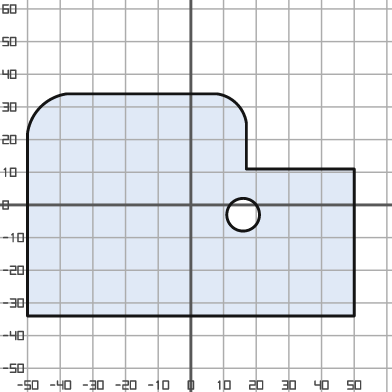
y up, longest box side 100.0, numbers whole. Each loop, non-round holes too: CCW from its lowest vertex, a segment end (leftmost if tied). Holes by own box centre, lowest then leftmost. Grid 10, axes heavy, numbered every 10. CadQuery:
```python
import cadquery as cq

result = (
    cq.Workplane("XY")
    .moveTo(-50.0, -34.0)
    .lineTo(50.0, -34.0)
    .lineTo(50.0, 11.0)
    .lineTo(17.0, 11.0)
    .lineTo(17.0, 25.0)
    .threePointArc((14.0, 31.0), (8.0, 34.0))
    .lineTo(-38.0, 34.0)
    .threePointArc((-46.0, 30.0), (-50.0, 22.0))
    .close()
    .moveTo(16.0, -3.0)
    .circle(5.0)
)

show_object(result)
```